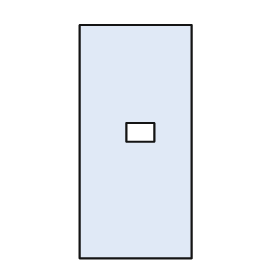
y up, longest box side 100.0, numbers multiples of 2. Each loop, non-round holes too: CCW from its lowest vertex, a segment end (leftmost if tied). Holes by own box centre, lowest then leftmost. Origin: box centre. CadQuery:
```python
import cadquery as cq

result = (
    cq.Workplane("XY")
    .moveTo(-24.0, -50.0)
    .lineTo(24.0, -50.0)
    .lineTo(24.0, 50.0)
    .lineTo(-24.0, 50.0)
    .close()
    .moveTo(-4.0, 0.0)
    .lineTo(8.0, 0.0)
    .lineTo(8.0, 8.0)
    .lineTo(-4.0, 8.0)
    .close()
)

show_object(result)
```